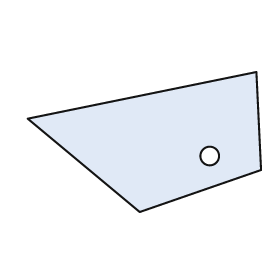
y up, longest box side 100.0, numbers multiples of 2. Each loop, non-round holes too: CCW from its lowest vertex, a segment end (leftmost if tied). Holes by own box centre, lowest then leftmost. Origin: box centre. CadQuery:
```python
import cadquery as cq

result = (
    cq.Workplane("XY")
    .moveTo(-2.0, -30.0)
    .lineTo(50.0, -12.0)
    .lineTo(48.0, 30.0)
    .lineTo(-50.0, 10.0)
    .close()
    .moveTo(28.0, -6.0)
    .circle(4.0)
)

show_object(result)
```